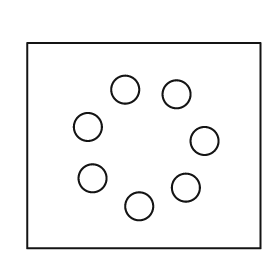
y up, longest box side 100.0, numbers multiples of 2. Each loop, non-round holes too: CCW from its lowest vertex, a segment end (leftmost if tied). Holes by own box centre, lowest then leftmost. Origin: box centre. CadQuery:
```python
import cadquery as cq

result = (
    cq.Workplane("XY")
    .moveTo(-50.0, -44.0)
    .lineTo(50.0, -44.0)
    .lineTo(50.0, 44.0)
    .lineTo(-50.0, 44.0)
    .close()
    .moveTo(-2.0, -26.0)
    .circle(6.0)
    .moveTo(18.0, -18.0)
    .circle(6.0)
    .moveTo(-22.0, -14.0)
    .circle(6.0)
    .moveTo(26.0, 2.0)
    .circle(6.0)
    .moveTo(-24.0, 8.0)
    .circle(6.0)
    .moveTo(14.0, 22.0)
    .circle(6.0)
    .moveTo(-8.0, 24.0)
    .circle(6.0)
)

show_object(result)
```